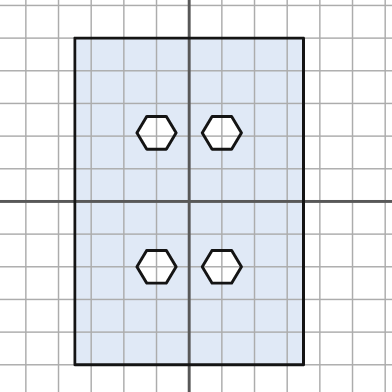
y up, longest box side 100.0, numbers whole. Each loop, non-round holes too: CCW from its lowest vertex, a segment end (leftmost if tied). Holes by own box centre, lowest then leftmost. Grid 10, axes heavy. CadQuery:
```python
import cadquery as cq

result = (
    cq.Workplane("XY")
    .moveTo(-35.0, -50.0)
    .lineTo(35.0, -50.0)
    .lineTo(35.0, 50.0)
    .lineTo(-35.0, 50.0)
    .close()
    .moveTo(-13.0, -25.0)
    .lineTo(-7.0, -25.0)
    .lineTo(-4.0, -20.0)
    .lineTo(-7.0, -15.0)
    .lineTo(-13.0, -15.0)
    .lineTo(-16.0, -20.0)
    .close()
    .moveTo(7.0, -25.0)
    .lineTo(13.0, -25.0)
    .lineTo(16.0, -20.0)
    .lineTo(13.0, -15.0)
    .lineTo(7.0, -15.0)
    .lineTo(4.0, -20.0)
    .close()
    .moveTo(-13.0, 16.0)
    .lineTo(-7.0, 16.0)
    .lineTo(-4.0, 21.0)
    .lineTo(-7.0, 26.0)
    .lineTo(-13.0, 26.0)
    .lineTo(-16.0, 21.0)
    .close()
    .moveTo(7.0, 16.0)
    .lineTo(13.0, 16.0)
    .lineTo(16.0, 21.0)
    .lineTo(13.0, 26.0)
    .lineTo(7.0, 26.0)
    .lineTo(4.0, 21.0)
    .close()
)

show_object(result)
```